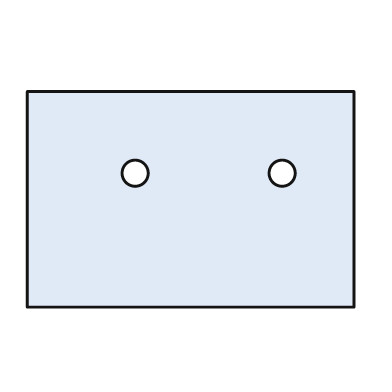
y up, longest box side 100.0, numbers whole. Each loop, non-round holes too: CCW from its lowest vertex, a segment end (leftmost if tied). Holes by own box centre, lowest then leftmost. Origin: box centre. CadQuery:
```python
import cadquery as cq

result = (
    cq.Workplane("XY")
    .moveTo(-50.0, -33.0)
    .lineTo(50.0, -33.0)
    .lineTo(50.0, 33.0)
    .lineTo(-50.0, 33.0)
    .close()
    .moveTo(-17.0, 8.0)
    .circle(4.0)
    .moveTo(28.0, 8.0)
    .circle(4.0)
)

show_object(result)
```